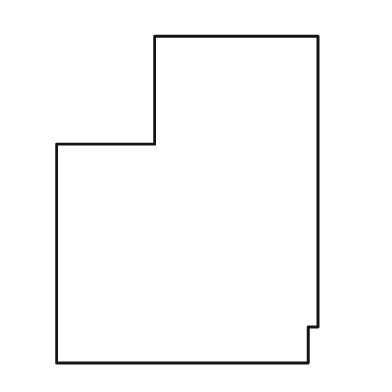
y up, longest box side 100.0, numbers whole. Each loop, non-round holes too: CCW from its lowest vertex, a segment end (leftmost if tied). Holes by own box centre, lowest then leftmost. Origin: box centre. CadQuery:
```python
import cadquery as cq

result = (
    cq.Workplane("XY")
    .moveTo(-40.0, -50.0)
    .lineTo(37.0, -50.0)
    .lineTo(37.0, -39.0)
    .lineTo(40.0, -39.0)
    .lineTo(40.0, 50.0)
    .lineTo(-10.0, 50.0)
    .lineTo(-10.0, 17.0)
    .lineTo(-40.0, 17.0)
    .close()
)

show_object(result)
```